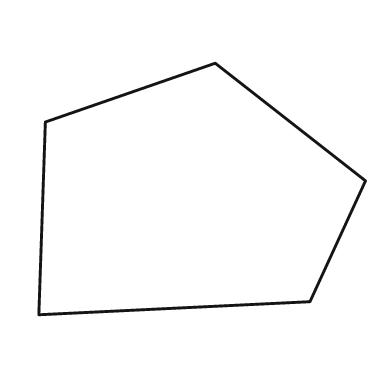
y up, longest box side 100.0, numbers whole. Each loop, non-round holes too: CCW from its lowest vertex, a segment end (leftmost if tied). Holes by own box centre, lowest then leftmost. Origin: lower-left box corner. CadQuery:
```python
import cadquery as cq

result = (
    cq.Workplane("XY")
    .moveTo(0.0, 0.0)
    .lineTo(83.0, 4.0)
    .lineTo(100.0, 41.0)
    .lineTo(54.0, 77.0)
    .lineTo(2.0, 59.0)
    .close()
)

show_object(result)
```